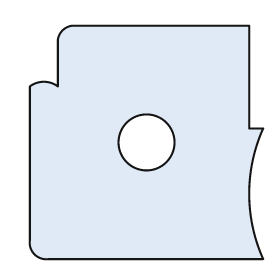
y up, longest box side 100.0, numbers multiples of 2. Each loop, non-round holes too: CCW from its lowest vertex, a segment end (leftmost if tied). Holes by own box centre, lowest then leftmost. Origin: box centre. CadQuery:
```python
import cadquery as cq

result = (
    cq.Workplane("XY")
    .moveTo(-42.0, -50.0)
    .lineTo(50.0, -50.0)
    .threePointArc((44.0, -22.0), (50.0, 6.0))
    .lineTo(44.0, 6.0)
    .lineTo(44.0, 50.0)
    .lineTo(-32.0, 50.0)
    .threePointArc((-36.0, 48.0), (-38.0, 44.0))
    .lineTo(-38.0, 24.0)
    .threePointArc((-44.0, 26.0), (-50.0, 24.0))
    .lineTo(-50.0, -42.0)
    .threePointArc((-48.0, -48.0), (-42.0, -50.0))
    .close()
    .moveTo(0.0, 0.0)
    .circle(12.0)
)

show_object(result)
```